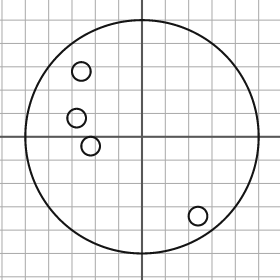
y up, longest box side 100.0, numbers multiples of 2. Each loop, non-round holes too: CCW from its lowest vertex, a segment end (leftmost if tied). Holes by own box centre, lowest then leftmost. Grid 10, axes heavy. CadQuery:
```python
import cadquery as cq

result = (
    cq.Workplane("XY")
    .moveTo(0.0, 0.0)
    .circle(50.0)
    .moveTo(24.0, -34.0)
    .circle(4.0)
    .moveTo(-22.0, -4.0)
    .circle(4.0)
    .moveTo(-28.0, 8.0)
    .circle(4.0)
    .moveTo(-26.0, 28.0)
    .circle(4.0)
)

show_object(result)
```